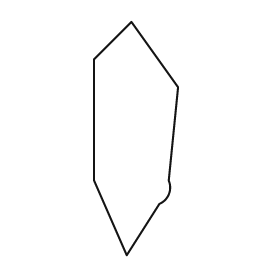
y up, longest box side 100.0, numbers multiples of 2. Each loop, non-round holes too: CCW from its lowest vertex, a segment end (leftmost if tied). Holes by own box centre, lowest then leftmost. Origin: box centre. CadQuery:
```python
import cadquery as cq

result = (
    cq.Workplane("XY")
    .moveTo(-4.0, -50.0)
    .lineTo(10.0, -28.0)
    .threePointArc((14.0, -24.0), (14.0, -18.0))
    .lineTo(18.0, 22.0)
    .lineTo(-2.0, 50.0)
    .lineTo(-18.0, 34.0)
    .lineTo(-18.0, -18.0)
    .close()
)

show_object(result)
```